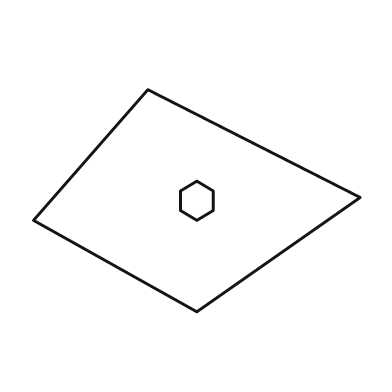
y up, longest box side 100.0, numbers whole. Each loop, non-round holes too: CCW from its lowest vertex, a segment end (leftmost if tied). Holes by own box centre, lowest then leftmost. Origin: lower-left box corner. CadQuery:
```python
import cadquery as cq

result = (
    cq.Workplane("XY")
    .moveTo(50.0, 0.0)
    .lineTo(100.0, 35.0)
    .lineTo(35.0, 68.0)
    .lineTo(0.0, 28.0)
    .close()
    .moveTo(50.0, 28.0)
    .lineTo(55.0, 31.0)
    .lineTo(55.0, 37.0)
    .lineTo(50.0, 40.0)
    .lineTo(45.0, 37.0)
    .lineTo(45.0, 31.0)
    .close()
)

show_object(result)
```